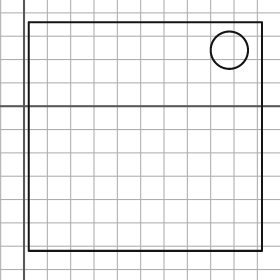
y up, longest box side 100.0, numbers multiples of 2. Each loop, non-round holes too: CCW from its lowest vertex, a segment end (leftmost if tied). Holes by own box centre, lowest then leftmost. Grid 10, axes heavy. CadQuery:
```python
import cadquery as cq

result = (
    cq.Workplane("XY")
    .moveTo(2.0, -62.0)
    .lineTo(102.0, -62.0)
    .lineTo(102.0, 36.0)
    .lineTo(2.0, 36.0)
    .close()
    .moveTo(88.0, 24.0)
    .circle(8.0)
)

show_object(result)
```